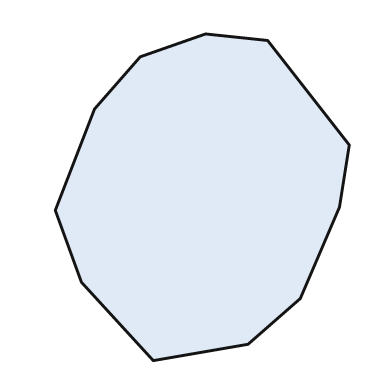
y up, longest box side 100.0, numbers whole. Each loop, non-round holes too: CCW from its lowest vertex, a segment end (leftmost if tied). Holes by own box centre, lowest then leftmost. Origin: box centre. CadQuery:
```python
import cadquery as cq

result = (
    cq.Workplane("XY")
    .moveTo(-15.0, -50.0)
    .lineTo(14.0, -45.0)
    .lineTo(30.0, -31.0)
    .lineTo(42.0, -3.0)
    .lineTo(45.0, 16.0)
    .lineTo(20.0, 48.0)
    .lineTo(1.0, 50.0)
    .lineTo(-19.0, 43.0)
    .lineTo(-33.0, 27.0)
    .lineTo(-45.0, -4.0)
    .lineTo(-37.0, -26.0)
    .close()
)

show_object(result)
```